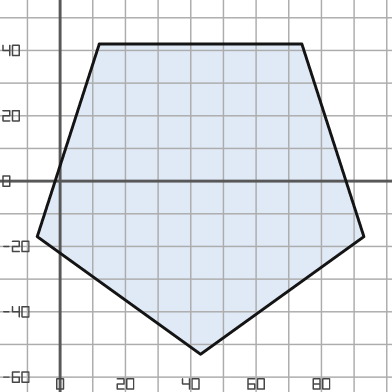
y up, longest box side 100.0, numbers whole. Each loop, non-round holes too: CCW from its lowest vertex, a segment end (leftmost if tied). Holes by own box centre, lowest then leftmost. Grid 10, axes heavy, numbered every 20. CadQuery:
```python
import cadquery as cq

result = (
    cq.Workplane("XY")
    .moveTo(43.0, -53.0)
    .lineTo(93.0, -17.0)
    .lineTo(74.0, 42.0)
    .lineTo(12.0, 42.0)
    .lineTo(-7.0, -17.0)
    .close()
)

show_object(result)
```